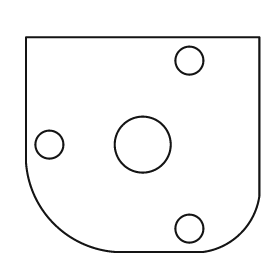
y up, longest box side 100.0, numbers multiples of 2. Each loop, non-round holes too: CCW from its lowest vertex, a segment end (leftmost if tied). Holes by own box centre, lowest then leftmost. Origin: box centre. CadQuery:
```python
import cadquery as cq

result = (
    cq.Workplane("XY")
    .moveTo(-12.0, -46.0)
    .lineTo(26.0, -46.0)
    .threePointArc((42.0, -38.0), (50.0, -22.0))
    .lineTo(50.0, 46.0)
    .lineTo(-50.0, 46.0)
    .lineTo(-50.0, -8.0)
    .threePointArc((-38.0, -34.0), (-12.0, -46.0))
    .close()
    .moveTo(20.0, -36.0)
    .circle(6.0)
    .moveTo(-40.0, 0.0)
    .circle(6.0)
    .moveTo(0.0, 0.0)
    .circle(12.0)
    .moveTo(20.0, 36.0)
    .circle(6.0)
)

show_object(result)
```